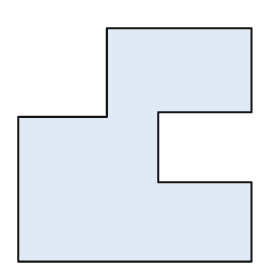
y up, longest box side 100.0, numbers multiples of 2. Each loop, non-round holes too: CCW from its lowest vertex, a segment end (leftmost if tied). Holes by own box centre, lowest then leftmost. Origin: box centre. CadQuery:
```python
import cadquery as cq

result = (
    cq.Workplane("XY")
    .moveTo(-50.0, -50.0)
    .lineTo(50.0, -50.0)
    .lineTo(50.0, -16.0)
    .lineTo(10.0, -16.0)
    .lineTo(10.0, 14.0)
    .lineTo(50.0, 14.0)
    .lineTo(50.0, 50.0)
    .lineTo(-12.0, 50.0)
    .lineTo(-12.0, 12.0)
    .lineTo(-50.0, 12.0)
    .close()
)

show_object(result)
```